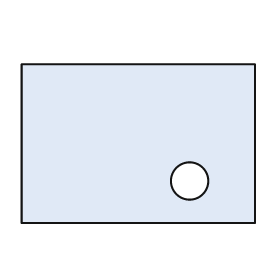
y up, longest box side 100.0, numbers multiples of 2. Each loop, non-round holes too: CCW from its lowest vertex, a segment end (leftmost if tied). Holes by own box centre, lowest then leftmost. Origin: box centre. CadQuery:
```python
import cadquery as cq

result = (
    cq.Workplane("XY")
    .moveTo(-50.0, -34.0)
    .lineTo(50.0, -34.0)
    .lineTo(50.0, 34.0)
    .lineTo(-50.0, 34.0)
    .close()
    .moveTo(22.0, -16.0)
    .circle(8.0)
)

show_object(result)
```